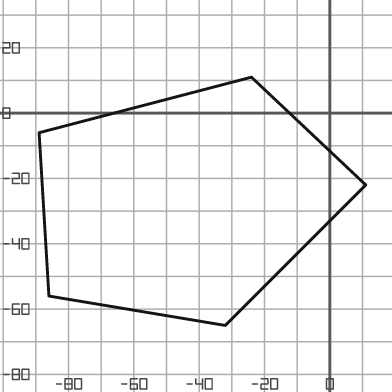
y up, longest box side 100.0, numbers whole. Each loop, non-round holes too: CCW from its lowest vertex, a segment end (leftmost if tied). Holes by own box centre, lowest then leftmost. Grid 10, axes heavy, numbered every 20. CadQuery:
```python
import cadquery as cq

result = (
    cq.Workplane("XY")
    .moveTo(-32.0, -65.0)
    .lineTo(11.0, -22.0)
    .lineTo(-24.0, 11.0)
    .lineTo(-89.0, -6.0)
    .lineTo(-86.0, -56.0)
    .close()
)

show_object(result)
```